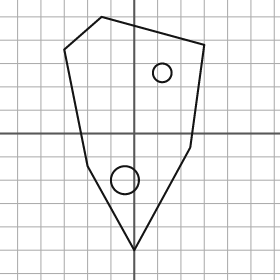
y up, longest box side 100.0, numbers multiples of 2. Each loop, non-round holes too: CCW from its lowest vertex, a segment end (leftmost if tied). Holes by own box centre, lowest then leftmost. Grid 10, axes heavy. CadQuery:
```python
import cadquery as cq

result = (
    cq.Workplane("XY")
    .moveTo(0.0, -50.0)
    .lineTo(24.0, -6.0)
    .lineTo(30.0, 38.0)
    .lineTo(-14.0, 50.0)
    .lineTo(-30.0, 36.0)
    .lineTo(-20.0, -14.0)
    .close()
    .moveTo(-4.0, -20.0)
    .circle(6.0)
    .moveTo(12.0, 26.0)
    .circle(4.0)
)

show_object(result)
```